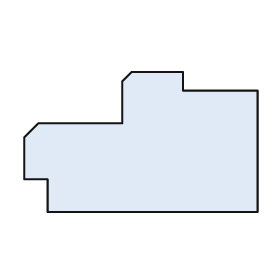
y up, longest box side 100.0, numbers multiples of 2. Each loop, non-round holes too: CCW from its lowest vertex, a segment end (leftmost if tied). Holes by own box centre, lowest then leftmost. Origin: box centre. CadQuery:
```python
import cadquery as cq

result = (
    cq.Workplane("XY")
    .moveTo(-40.0, -30.0)
    .lineTo(50.0, -30.0)
    .lineTo(50.0, 22.0)
    .lineTo(18.0, 22.0)
    .lineTo(18.0, 30.0)
    .lineTo(-4.0, 30.0)
    .lineTo(-8.0, 26.0)
    .lineTo(-8.0, 8.0)
    .lineTo(-44.0, 8.0)
    .lineTo(-50.0, 2.0)
    .lineTo(-50.0, -16.0)
    .lineTo(-40.0, -16.0)
    .close()
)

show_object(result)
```